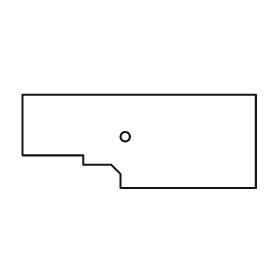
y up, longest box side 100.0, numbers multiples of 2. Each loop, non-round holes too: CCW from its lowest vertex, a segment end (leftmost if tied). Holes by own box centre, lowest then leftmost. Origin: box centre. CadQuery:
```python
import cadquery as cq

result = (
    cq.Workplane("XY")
    .moveTo(-8.0, -20.0)
    .lineTo(50.0, -20.0)
    .lineTo(50.0, 20.0)
    .lineTo(-50.0, 20.0)
    .lineTo(-50.0, -6.0)
    .lineTo(-24.0, -6.0)
    .lineTo(-24.0, -10.0)
    .lineTo(-12.0, -10.0)
    .lineTo(-8.0, -14.0)
    .close()
    .moveTo(-6.0, 2.0)
    .circle(2.0)
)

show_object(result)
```